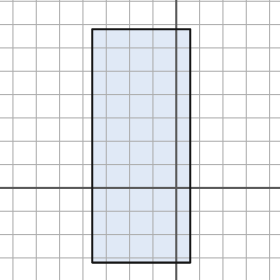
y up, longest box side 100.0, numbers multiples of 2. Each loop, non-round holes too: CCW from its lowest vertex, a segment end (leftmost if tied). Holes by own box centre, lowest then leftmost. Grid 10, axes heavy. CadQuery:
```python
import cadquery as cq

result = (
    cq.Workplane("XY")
    .moveTo(-36.0, -32.0)
    .lineTo(6.0, -32.0)
    .lineTo(6.0, 68.0)
    .lineTo(-36.0, 68.0)
    .close()
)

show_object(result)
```